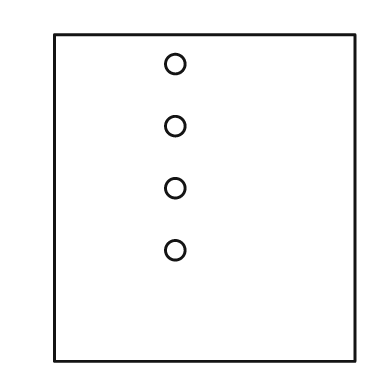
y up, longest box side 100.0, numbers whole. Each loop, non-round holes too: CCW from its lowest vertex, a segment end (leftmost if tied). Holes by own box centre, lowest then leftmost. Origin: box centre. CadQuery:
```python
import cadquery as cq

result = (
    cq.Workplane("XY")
    .moveTo(-46.0, -50.0)
    .lineTo(46.0, -50.0)
    .lineTo(46.0, 50.0)
    .lineTo(-46.0, 50.0)
    .close()
    .moveTo(-9.0, -16.0)
    .circle(3.0)
    .moveTo(-9.0, 3.0)
    .circle(3.0)
    .moveTo(-9.0, 22.0)
    .circle(3.0)
    .moveTo(-9.0, 41.0)
    .circle(3.0)
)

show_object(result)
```